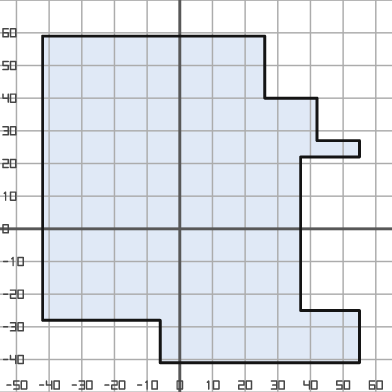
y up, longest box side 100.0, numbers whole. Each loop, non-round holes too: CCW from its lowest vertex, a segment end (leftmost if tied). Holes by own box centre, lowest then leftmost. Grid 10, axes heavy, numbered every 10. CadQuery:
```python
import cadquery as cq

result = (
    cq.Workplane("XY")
    .moveTo(-6.0, -41.0)
    .lineTo(55.0, -41.0)
    .lineTo(55.0, -25.0)
    .lineTo(37.0, -25.0)
    .lineTo(37.0, 22.0)
    .lineTo(55.0, 22.0)
    .lineTo(55.0, 27.0)
    .lineTo(42.0, 27.0)
    .lineTo(42.0, 40.0)
    .lineTo(26.0, 40.0)
    .lineTo(26.0, 59.0)
    .lineTo(-42.0, 59.0)
    .lineTo(-42.0, -28.0)
    .lineTo(-6.0, -28.0)
    .close()
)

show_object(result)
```